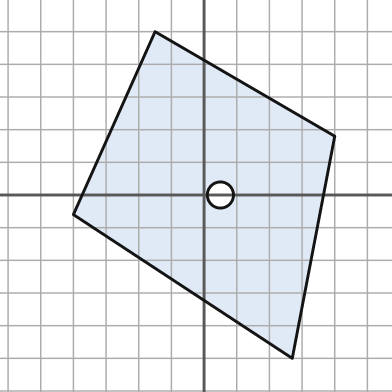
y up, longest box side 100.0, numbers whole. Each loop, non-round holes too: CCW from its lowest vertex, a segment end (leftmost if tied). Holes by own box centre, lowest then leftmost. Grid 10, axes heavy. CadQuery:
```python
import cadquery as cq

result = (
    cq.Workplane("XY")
    .moveTo(27.0, -50.0)
    .lineTo(40.0, 18.0)
    .lineTo(-15.0, 50.0)
    .lineTo(-40.0, -6.0)
    .close()
    .moveTo(5.0, 0.0)
    .circle(4.0)
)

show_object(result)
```